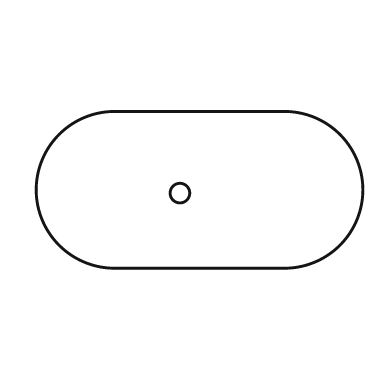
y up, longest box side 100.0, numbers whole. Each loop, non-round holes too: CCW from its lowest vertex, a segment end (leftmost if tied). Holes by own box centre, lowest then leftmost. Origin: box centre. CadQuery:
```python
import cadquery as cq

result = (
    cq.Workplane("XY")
    .moveTo(-26.0, -24.0)
    .lineTo(26.0, -24.0)
    .threePointArc((50.0, 0.0), (26.0, 24.0))
    .lineTo(-26.0, 24.0)
    .threePointArc((-50.0, 0.0), (-26.0, -24.0))
    .close()
    .moveTo(-6.0, -1.0)
    .circle(3.0)
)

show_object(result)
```